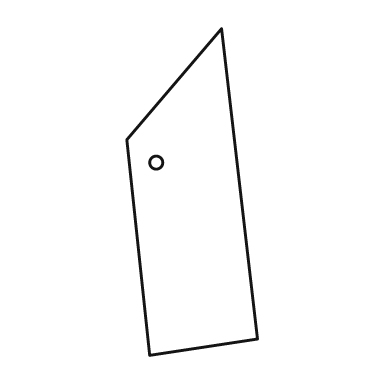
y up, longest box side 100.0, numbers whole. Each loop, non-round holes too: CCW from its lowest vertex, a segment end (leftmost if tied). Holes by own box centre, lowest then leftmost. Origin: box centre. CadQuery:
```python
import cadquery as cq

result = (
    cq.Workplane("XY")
    .moveTo(-13.0, -50.0)
    .lineTo(20.0, -45.0)
    .lineTo(9.0, 50.0)
    .lineTo(-20.0, 16.0)
    .close()
    .moveTo(-11.0, 9.0)
    .circle(2.0)
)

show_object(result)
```